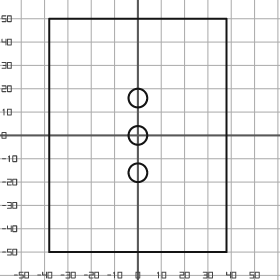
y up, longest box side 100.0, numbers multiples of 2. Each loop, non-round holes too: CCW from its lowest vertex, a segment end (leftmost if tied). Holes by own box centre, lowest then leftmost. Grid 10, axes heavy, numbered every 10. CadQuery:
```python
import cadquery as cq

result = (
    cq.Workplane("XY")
    .moveTo(-38.0, -50.0)
    .lineTo(38.0, -50.0)
    .lineTo(38.0, 50.0)
    .lineTo(-38.0, 50.0)
    .close()
    .moveTo(0.0, -16.0)
    .circle(4.0)
    .moveTo(0.0, 0.0)
    .circle(4.0)
    .moveTo(0.0, 16.0)
    .circle(4.0)
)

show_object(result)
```